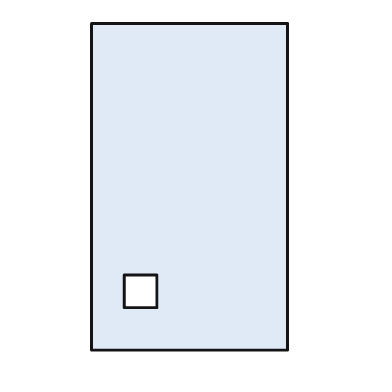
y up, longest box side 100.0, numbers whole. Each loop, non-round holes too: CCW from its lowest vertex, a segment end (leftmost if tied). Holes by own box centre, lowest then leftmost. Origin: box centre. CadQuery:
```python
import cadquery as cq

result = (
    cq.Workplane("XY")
    .moveTo(-30.0, -50.0)
    .lineTo(30.0, -50.0)
    .lineTo(30.0, 50.0)
    .lineTo(-30.0, 50.0)
    .close()
    .moveTo(-20.0, -37.0)
    .lineTo(-10.0, -37.0)
    .lineTo(-10.0, -27.0)
    .lineTo(-20.0, -27.0)
    .close()
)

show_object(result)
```